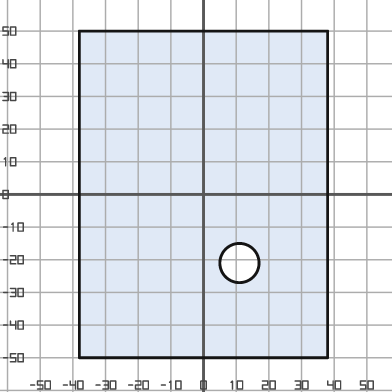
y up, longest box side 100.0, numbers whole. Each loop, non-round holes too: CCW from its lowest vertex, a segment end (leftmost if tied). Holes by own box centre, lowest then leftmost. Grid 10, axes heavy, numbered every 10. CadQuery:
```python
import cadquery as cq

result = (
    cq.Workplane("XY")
    .moveTo(-38.0, -50.0)
    .lineTo(38.0, -50.0)
    .lineTo(38.0, 50.0)
    .lineTo(-38.0, 50.0)
    .close()
    .moveTo(11.0, -21.0)
    .circle(6.0)
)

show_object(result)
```